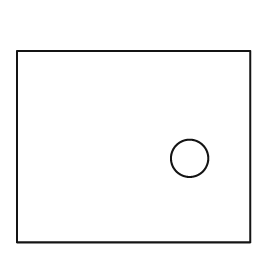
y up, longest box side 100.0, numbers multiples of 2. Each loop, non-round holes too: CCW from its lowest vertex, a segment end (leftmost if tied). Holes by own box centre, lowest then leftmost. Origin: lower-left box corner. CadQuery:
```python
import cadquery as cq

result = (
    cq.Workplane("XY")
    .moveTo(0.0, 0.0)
    .lineTo(100.0, 0.0)
    .lineTo(100.0, 82.0)
    .lineTo(0.0, 82.0)
    .close()
    .moveTo(74.0, 36.0)
    .circle(8.0)
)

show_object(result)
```